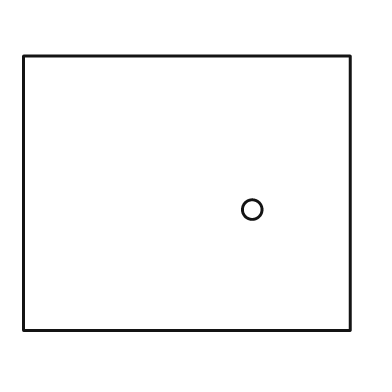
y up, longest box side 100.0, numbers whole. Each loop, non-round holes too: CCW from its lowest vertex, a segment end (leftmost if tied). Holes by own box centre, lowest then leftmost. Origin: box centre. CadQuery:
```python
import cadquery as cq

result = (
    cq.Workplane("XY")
    .moveTo(-50.0, -42.0)
    .lineTo(50.0, -42.0)
    .lineTo(50.0, 42.0)
    .lineTo(-50.0, 42.0)
    .close()
    .moveTo(20.0, -5.0)
    .circle(3.0)
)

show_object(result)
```